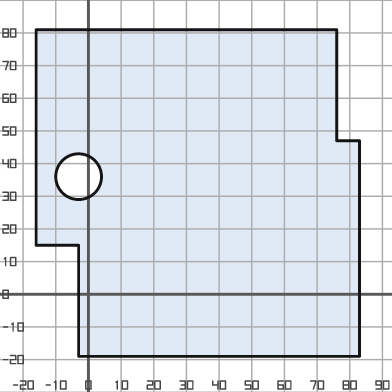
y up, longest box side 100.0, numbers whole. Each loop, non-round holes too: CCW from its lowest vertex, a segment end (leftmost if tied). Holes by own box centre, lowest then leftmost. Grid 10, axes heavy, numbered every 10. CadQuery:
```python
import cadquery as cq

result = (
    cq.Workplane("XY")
    .moveTo(-3.0, -19.0)
    .lineTo(83.0, -19.0)
    .lineTo(83.0, 47.0)
    .lineTo(76.0, 47.0)
    .lineTo(76.0, 81.0)
    .lineTo(-16.0, 81.0)
    .lineTo(-16.0, 15.0)
    .lineTo(-3.0, 15.0)
    .close()
    .moveTo(-3.0, 36.0)
    .circle(7.0)
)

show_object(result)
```